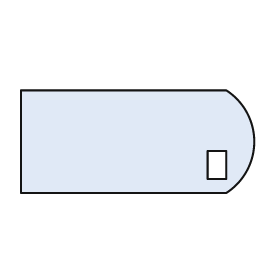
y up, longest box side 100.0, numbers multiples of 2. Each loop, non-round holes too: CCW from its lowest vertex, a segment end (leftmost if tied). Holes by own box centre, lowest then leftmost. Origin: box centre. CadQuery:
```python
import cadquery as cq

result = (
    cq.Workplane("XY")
    .moveTo(-50.0, -22.0)
    .lineTo(38.0, -22.0)
    .threePointArc((50.0, 0.0), (38.0, 22.0))
    .lineTo(-50.0, 22.0)
    .close()
    .moveTo(30.0, -16.0)
    .lineTo(38.0, -16.0)
    .lineTo(38.0, -4.0)
    .lineTo(30.0, -4.0)
    .close()
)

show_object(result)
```